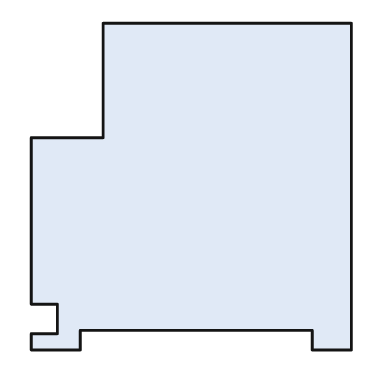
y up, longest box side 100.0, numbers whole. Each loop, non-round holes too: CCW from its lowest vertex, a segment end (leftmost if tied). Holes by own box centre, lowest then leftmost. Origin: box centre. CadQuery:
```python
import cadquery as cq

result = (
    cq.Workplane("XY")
    .moveTo(-49.0, -50.0)
    .lineTo(-34.0, -50.0)
    .lineTo(-34.0, -44.0)
    .lineTo(37.0, -44.0)
    .lineTo(37.0, -50.0)
    .lineTo(49.0, -50.0)
    .lineTo(49.0, 50.0)
    .lineTo(-27.0, 50.0)
    .lineTo(-27.0, 15.0)
    .lineTo(-49.0, 15.0)
    .lineTo(-49.0, -36.0)
    .lineTo(-41.0, -36.0)
    .lineTo(-41.0, -45.0)
    .lineTo(-49.0, -45.0)
    .close()
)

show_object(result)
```